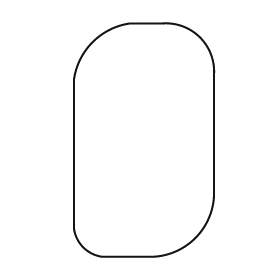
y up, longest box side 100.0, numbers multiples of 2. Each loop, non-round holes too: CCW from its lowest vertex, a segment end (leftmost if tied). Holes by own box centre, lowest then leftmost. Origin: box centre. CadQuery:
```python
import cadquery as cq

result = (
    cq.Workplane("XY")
    .moveTo(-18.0, -50.0)
    .lineTo(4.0, -50.0)
    .threePointArc((22.0, -42.0), (30.0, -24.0))
    .lineTo(30.0, 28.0)
    .threePointArc((24.0, 44.0), (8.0, 50.0))
    .lineTo(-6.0, 50.0)
    .threePointArc((-22.0, 42.0), (-30.0, 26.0))
    .lineTo(-30.0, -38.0)
    .threePointArc((-26.0, -46.0), (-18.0, -50.0))
    .close()
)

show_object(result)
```